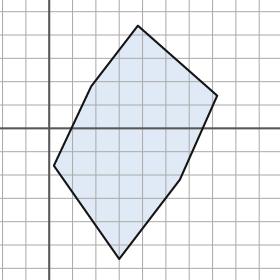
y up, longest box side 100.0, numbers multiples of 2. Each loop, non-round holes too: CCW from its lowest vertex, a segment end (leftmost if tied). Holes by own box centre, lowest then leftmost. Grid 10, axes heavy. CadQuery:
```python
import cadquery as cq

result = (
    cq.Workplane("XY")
    .moveTo(30.0, -56.0)
    .lineTo(56.0, -22.0)
    .lineTo(72.0, 14.0)
    .lineTo(38.0, 44.0)
    .lineTo(18.0, 18.0)
    .lineTo(2.0, -16.0)
    .close()
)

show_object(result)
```